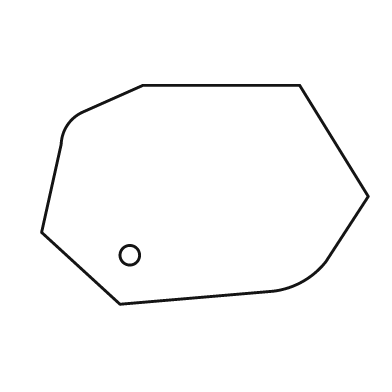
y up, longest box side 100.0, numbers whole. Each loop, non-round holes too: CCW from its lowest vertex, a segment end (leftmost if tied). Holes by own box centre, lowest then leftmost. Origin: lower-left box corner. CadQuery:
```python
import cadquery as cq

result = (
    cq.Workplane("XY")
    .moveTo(24.0, 0.0)
    .lineTo(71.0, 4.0)
    .threePointArc((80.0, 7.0), (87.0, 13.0))
    .lineTo(100.0, 33.0)
    .lineTo(79.0, 67.0)
    .lineTo(31.0, 67.0)
    .lineTo(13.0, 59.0)
    .threePointArc((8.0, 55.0), (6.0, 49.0))
    .lineTo(0.0, 22.0)
    .close()
    .moveTo(27.0, 15.0)
    .circle(3.0)
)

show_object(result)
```